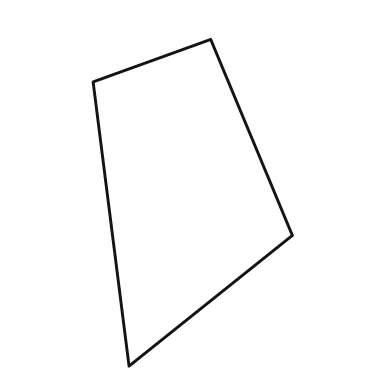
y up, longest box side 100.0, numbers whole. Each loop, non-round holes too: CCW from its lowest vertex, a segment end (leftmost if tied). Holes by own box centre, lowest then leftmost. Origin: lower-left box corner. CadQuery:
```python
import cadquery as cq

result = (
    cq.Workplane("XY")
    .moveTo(11.0, 0.0)
    .lineTo(61.0, 40.0)
    .lineTo(36.0, 100.0)
    .lineTo(0.0, 87.0)
    .close()
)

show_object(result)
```